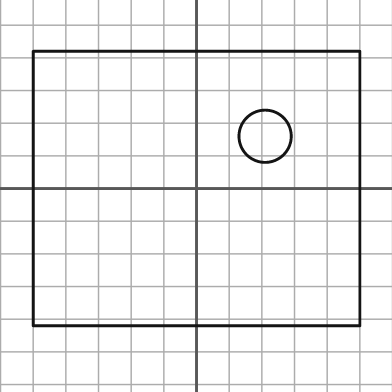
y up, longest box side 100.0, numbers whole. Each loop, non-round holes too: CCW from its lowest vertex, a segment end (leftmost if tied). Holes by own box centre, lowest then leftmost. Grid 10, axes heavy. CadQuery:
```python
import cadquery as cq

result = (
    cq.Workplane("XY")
    .moveTo(-50.0, -42.0)
    .lineTo(50.0, -42.0)
    .lineTo(50.0, 42.0)
    .lineTo(-50.0, 42.0)
    .close()
    .moveTo(21.0, 16.0)
    .circle(8.0)
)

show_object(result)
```